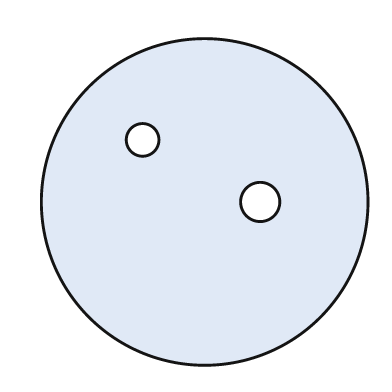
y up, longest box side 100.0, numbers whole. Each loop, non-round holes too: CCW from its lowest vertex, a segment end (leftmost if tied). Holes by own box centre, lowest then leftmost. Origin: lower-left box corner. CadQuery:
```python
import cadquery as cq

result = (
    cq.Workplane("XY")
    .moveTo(50.0, 50.0)
    .circle(50.0)
    .moveTo(67.0, 50.0)
    .circle(6.0)
    .moveTo(31.0, 69.0)
    .circle(5.0)
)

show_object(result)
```